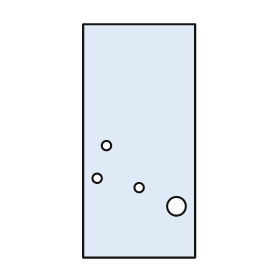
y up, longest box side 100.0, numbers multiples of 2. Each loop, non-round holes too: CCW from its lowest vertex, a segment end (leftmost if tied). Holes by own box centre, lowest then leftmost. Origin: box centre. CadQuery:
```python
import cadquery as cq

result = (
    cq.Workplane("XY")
    .moveTo(-24.0, -50.0)
    .lineTo(24.0, -50.0)
    .lineTo(24.0, 50.0)
    .lineTo(-24.0, 50.0)
    .close()
    .moveTo(16.0, -28.0)
    .circle(4.0)
    .moveTo(0.0, -20.0)
    .circle(2.0)
    .moveTo(-18.0, -16.0)
    .circle(2.0)
    .moveTo(-14.0, -2.0)
    .circle(2.0)
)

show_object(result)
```